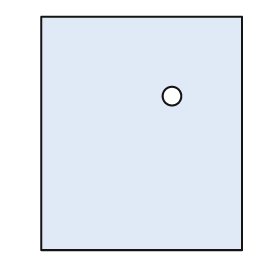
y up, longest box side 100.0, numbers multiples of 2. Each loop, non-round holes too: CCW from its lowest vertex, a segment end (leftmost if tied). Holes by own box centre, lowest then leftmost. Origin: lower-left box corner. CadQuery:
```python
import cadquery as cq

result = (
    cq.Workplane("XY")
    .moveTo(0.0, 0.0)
    .lineTo(86.0, 0.0)
    .lineTo(86.0, 100.0)
    .lineTo(0.0, 100.0)
    .close()
    .moveTo(56.0, 66.0)
    .circle(4.0)
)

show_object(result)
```